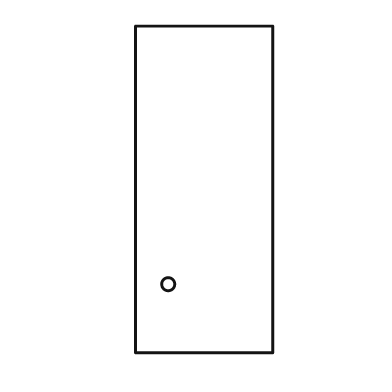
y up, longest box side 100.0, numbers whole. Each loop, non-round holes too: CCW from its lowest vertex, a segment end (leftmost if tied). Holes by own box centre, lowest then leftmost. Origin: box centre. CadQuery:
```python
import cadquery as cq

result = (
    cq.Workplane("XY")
    .moveTo(-21.0, -50.0)
    .lineTo(21.0, -50.0)
    .lineTo(21.0, 50.0)
    .lineTo(-21.0, 50.0)
    .close()
    .moveTo(-11.0, -29.0)
    .circle(2.0)
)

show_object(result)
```